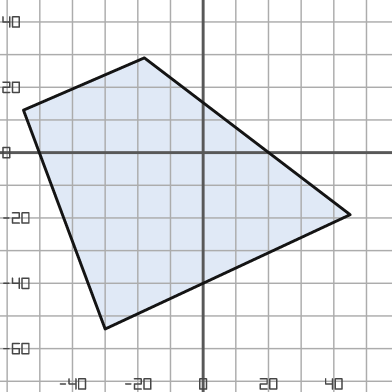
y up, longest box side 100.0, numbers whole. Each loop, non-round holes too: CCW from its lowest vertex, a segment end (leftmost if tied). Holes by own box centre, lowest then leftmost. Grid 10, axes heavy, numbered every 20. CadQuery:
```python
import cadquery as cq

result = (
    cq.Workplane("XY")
    .moveTo(-30.0, -54.0)
    .lineTo(45.0, -19.0)
    .lineTo(-18.0, 29.0)
    .lineTo(-55.0, 13.0)
    .close()
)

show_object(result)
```